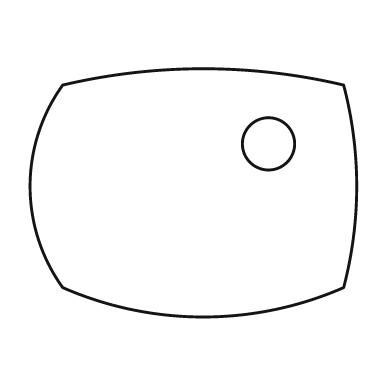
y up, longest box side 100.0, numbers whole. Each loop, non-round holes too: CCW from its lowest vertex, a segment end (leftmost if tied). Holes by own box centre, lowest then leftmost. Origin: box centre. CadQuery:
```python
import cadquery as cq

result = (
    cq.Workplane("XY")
    .moveTo(-40.0, -29.0)
    .threePointArc((3.0, -38.0), (46.0, -29.0))
    .threePointArc((50.0, 2.0), (46.0, 33.0))
    .threePointArc((3.0, 38.0), (-40.0, 33.0))
    .threePointArc((-50.0, 2.0), (-40.0, -29.0))
    .close()
    .moveTo(23.0, 15.0)
    .circle(8.0)
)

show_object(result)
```